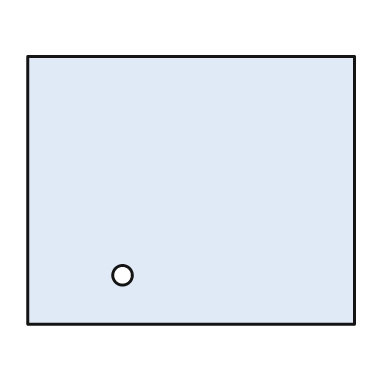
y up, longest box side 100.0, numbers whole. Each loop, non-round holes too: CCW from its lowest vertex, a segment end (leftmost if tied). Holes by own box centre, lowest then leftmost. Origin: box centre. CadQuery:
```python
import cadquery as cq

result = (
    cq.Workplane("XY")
    .moveTo(-50.0, -41.0)
    .lineTo(50.0, -41.0)
    .lineTo(50.0, 41.0)
    .lineTo(-50.0, 41.0)
    .close()
    .moveTo(-21.0, -26.0)
    .circle(3.0)
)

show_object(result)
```